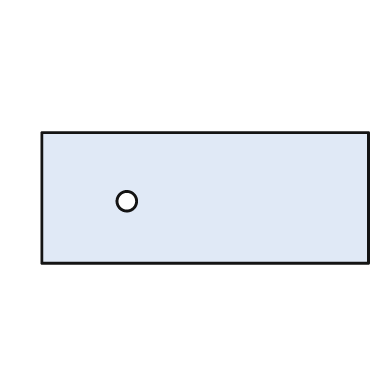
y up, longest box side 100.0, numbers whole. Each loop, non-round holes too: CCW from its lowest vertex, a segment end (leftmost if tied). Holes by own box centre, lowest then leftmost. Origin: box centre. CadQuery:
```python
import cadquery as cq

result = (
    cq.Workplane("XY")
    .moveTo(-50.0, -20.0)
    .lineTo(50.0, -20.0)
    .lineTo(50.0, 20.0)
    .lineTo(-50.0, 20.0)
    .close()
    .moveTo(-24.0, -1.0)
    .circle(3.0)
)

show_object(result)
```